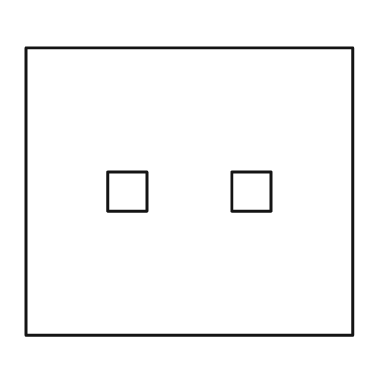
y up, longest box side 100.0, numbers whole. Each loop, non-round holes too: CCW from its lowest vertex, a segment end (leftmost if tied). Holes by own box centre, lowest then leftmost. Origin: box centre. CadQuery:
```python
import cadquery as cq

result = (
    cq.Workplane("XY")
    .moveTo(-50.0, -44.0)
    .lineTo(50.0, -44.0)
    .lineTo(50.0, 44.0)
    .lineTo(-50.0, 44.0)
    .close()
    .moveTo(-25.0, -6.0)
    .lineTo(-13.0, -6.0)
    .lineTo(-13.0, 6.0)
    .lineTo(-25.0, 6.0)
    .close()
    .moveTo(13.0, -6.0)
    .lineTo(25.0, -6.0)
    .lineTo(25.0, 6.0)
    .lineTo(13.0, 6.0)
    .close()
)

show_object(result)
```